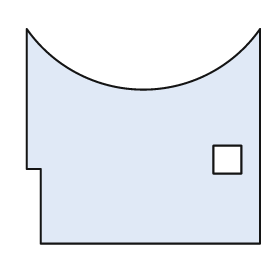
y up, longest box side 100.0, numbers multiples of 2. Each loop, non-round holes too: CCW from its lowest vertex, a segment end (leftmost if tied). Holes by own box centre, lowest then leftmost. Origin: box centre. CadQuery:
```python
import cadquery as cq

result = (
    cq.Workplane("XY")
    .moveTo(-44.0, -46.0)
    .lineTo(50.0, -46.0)
    .lineTo(50.0, 46.0)
    .threePointArc((0.0, 20.0), (-50.0, 46.0))
    .lineTo(-50.0, -14.0)
    .lineTo(-44.0, -14.0)
    .close()
    .moveTo(30.0, -16.0)
    .lineTo(42.0, -16.0)
    .lineTo(42.0, -4.0)
    .lineTo(30.0, -4.0)
    .close()
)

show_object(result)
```